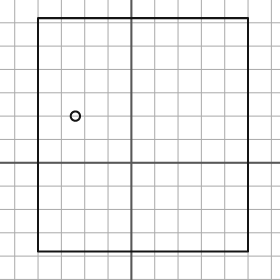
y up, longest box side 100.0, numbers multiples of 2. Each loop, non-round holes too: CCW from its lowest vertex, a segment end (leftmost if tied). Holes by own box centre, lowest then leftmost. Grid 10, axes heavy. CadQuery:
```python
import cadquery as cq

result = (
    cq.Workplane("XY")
    .moveTo(-40.0, -38.0)
    .lineTo(50.0, -38.0)
    .lineTo(50.0, 62.0)
    .lineTo(-40.0, 62.0)
    .close()
    .moveTo(-24.0, 20.0)
    .circle(2.0)
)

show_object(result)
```